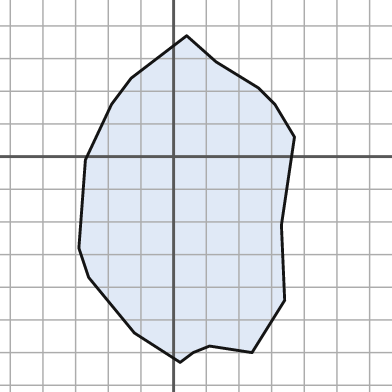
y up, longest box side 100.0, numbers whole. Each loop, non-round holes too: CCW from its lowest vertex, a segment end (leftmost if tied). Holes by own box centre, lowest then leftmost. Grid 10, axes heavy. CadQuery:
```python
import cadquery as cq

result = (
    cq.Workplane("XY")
    .moveTo(2.0, -63.0)
    .lineTo(6.0, -60.0)
    .lineTo(11.0, -58.0)
    .lineTo(24.0, -60.0)
    .lineTo(34.0, -44.0)
    .lineTo(33.0, -21.0)
    .lineTo(37.0, 6.0)
    .lineTo(31.0, 16.0)
    .lineTo(26.0, 21.0)
    .lineTo(13.0, 29.0)
    .lineTo(4.0, 37.0)
    .lineTo(-13.0, 24.0)
    .lineTo(-19.0, 16.0)
    .lineTo(-27.0, -1.0)
    .lineTo(-29.0, -28.0)
    .lineTo(-26.0, -37.0)
    .lineTo(-12.0, -54.0)
    .close()
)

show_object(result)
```